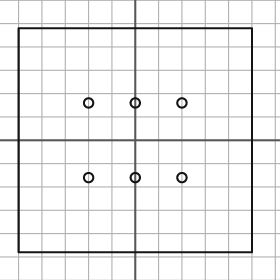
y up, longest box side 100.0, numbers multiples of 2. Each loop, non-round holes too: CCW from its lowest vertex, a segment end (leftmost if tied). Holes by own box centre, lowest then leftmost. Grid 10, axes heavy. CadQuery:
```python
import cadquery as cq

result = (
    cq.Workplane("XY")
    .moveTo(-50.0, -48.0)
    .lineTo(50.0, -48.0)
    .lineTo(50.0, 48.0)
    .lineTo(-50.0, 48.0)
    .close()
    .moveTo(-20.0, -16.0)
    .circle(2.0)
    .moveTo(0.0, -16.0)
    .circle(2.0)
    .moveTo(20.0, -16.0)
    .circle(2.0)
    .moveTo(-20.0, 16.0)
    .circle(2.0)
    .moveTo(0.0, 16.0)
    .circle(2.0)
    .moveTo(20.0, 16.0)
    .circle(2.0)
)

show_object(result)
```